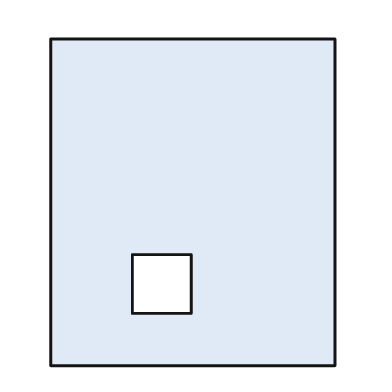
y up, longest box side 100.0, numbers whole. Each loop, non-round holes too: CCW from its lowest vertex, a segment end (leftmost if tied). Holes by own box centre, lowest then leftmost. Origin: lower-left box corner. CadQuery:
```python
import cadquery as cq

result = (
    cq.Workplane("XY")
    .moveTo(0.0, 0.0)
    .lineTo(87.0, 0.0)
    .lineTo(87.0, 100.0)
    .lineTo(0.0, 100.0)
    .close()
    .moveTo(25.0, 16.0)
    .lineTo(43.0, 16.0)
    .lineTo(43.0, 34.0)
    .lineTo(25.0, 34.0)
    .close()
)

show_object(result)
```